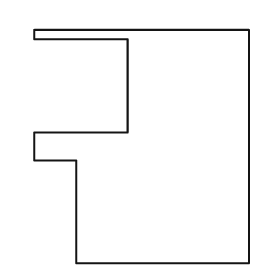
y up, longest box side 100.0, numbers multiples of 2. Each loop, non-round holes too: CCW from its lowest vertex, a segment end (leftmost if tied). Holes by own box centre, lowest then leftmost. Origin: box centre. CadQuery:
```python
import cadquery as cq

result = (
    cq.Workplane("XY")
    .moveTo(-28.0, -50.0)
    .lineTo(46.0, -50.0)
    .lineTo(46.0, 50.0)
    .lineTo(-46.0, 50.0)
    .lineTo(-46.0, 46.0)
    .lineTo(-6.0, 46.0)
    .lineTo(-6.0, 6.0)
    .lineTo(-46.0, 6.0)
    .lineTo(-46.0, -6.0)
    .lineTo(-28.0, -6.0)
    .close()
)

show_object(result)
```